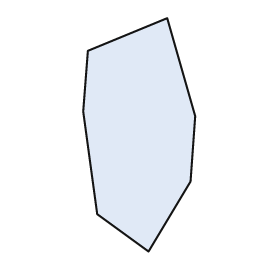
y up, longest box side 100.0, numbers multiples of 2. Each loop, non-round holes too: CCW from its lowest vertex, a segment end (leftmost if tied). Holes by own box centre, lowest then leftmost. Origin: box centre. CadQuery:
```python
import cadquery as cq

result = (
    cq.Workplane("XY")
    .moveTo(4.0, -50.0)
    .lineTo(22.0, -20.0)
    .lineTo(24.0, 8.0)
    .lineTo(12.0, 50.0)
    .lineTo(-22.0, 36.0)
    .lineTo(-24.0, 10.0)
    .lineTo(-18.0, -34.0)
    .close()
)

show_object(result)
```